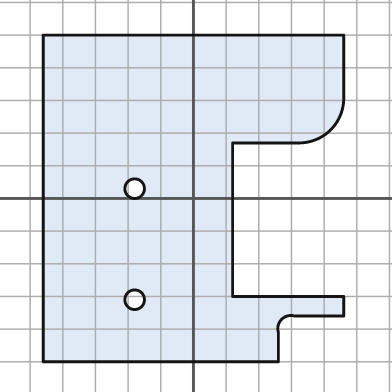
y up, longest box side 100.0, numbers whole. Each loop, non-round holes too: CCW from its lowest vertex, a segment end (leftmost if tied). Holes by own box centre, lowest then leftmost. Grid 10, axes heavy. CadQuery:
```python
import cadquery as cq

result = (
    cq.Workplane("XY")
    .moveTo(-46.0, -50.0)
    .lineTo(26.0, -50.0)
    .lineTo(26.0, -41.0)
    .threePointArc((27.0, -37.0), (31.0, -36.0))
    .lineTo(46.0, -36.0)
    .lineTo(46.0, -30.0)
    .lineTo(12.0, -30.0)
    .lineTo(12.0, 17.0)
    .lineTo(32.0, 17.0)
    .threePointArc((42.0, 21.0), (46.0, 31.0))
    .lineTo(46.0, 50.0)
    .lineTo(-46.0, 50.0)
    .close()
    .moveTo(-18.0, -31.0)
    .circle(3.0)
    .moveTo(-18.0, 3.0)
    .circle(3.0)
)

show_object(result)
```